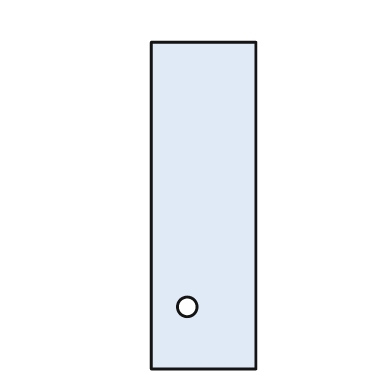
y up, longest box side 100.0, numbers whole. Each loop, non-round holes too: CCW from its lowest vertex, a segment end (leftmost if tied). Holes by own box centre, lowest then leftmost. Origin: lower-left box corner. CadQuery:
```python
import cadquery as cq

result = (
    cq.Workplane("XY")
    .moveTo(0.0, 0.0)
    .lineTo(32.0, 0.0)
    .lineTo(32.0, 100.0)
    .lineTo(0.0, 100.0)
    .close()
    .moveTo(11.0, 19.0)
    .circle(3.0)
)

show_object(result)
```